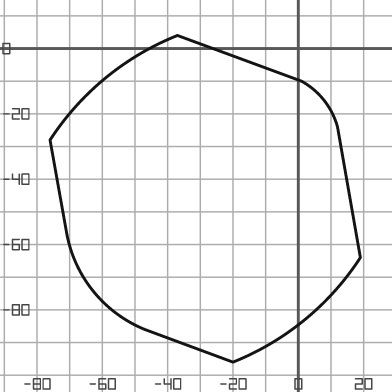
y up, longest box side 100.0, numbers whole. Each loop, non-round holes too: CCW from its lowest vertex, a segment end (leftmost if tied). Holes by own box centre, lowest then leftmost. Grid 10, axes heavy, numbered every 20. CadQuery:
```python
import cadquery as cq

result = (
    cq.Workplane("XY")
    .moveTo(-20.0, -96.0)
    .threePointArc((2.0, -83.0), (19.0, -64.0))
    .lineTo(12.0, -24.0)
    .threePointArc((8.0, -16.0), (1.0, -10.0))
    .lineTo(-37.0, 4.0)
    .threePointArc((-59.0, -9.0), (-76.0, -28.0))
    .lineTo(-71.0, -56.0)
    .threePointArc((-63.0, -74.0), (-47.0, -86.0))
    .close()
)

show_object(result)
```